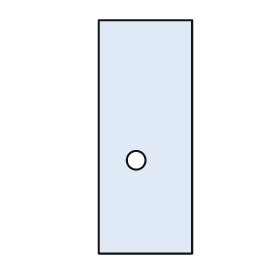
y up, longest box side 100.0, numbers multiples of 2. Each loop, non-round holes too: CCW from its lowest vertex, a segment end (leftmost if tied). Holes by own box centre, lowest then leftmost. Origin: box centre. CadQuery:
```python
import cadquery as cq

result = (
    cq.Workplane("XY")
    .moveTo(-20.0, -50.0)
    .lineTo(20.0, -50.0)
    .lineTo(20.0, 50.0)
    .lineTo(-20.0, 50.0)
    .close()
    .moveTo(-4.0, -10.0)
    .circle(4.0)
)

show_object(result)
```